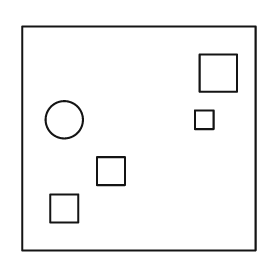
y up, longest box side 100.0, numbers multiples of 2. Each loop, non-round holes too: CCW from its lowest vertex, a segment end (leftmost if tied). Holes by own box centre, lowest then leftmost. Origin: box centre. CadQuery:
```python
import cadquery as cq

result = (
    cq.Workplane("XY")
    .moveTo(-50.0, -48.0)
    .lineTo(50.0, -48.0)
    .lineTo(50.0, 48.0)
    .lineTo(-50.0, 48.0)
    .close()
    .moveTo(-38.0, -36.0)
    .lineTo(-26.0, -36.0)
    .lineTo(-26.0, -24.0)
    .lineTo(-38.0, -24.0)
    .close()
    .moveTo(-18.0, -20.0)
    .lineTo(-6.0, -20.0)
    .lineTo(-6.0, -8.0)
    .lineTo(-18.0, -8.0)
    .close()
    .moveTo(-32.0, 8.0)
    .circle(8.0)
    .moveTo(24.0, 4.0)
    .lineTo(32.0, 4.0)
    .lineTo(32.0, 12.0)
    .lineTo(24.0, 12.0)
    .close()
    .moveTo(26.0, 20.0)
    .lineTo(42.0, 20.0)
    .lineTo(42.0, 36.0)
    .lineTo(26.0, 36.0)
    .close()
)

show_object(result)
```